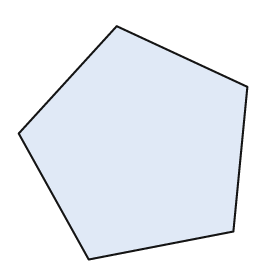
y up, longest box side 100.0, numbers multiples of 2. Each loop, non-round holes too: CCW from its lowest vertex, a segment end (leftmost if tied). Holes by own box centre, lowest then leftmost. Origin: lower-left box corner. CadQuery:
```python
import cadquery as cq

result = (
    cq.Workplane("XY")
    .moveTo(30.0, 0.0)
    .lineTo(92.0, 12.0)
    .lineTo(98.0, 74.0)
    .lineTo(42.0, 100.0)
    .lineTo(0.0, 54.0)
    .close()
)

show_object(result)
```